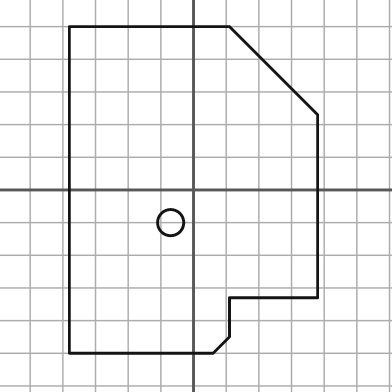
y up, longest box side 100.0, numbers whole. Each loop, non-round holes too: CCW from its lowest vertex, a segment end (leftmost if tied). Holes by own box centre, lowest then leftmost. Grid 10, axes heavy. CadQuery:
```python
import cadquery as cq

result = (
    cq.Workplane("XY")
    .moveTo(-38.0, -50.0)
    .lineTo(6.0, -50.0)
    .lineTo(11.0, -45.0)
    .lineTo(11.0, -33.0)
    .lineTo(38.0, -33.0)
    .lineTo(38.0, 23.0)
    .lineTo(11.0, 50.0)
    .lineTo(-38.0, 50.0)
    .close()
    .moveTo(-7.0, -10.0)
    .circle(4.0)
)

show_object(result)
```